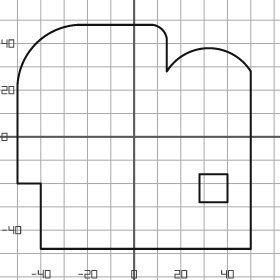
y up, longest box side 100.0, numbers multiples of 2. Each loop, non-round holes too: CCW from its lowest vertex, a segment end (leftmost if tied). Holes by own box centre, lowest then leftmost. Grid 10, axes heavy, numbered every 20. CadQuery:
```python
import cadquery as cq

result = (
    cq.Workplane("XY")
    .moveTo(-40.0, -48.0)
    .lineTo(50.0, -48.0)
    .lineTo(50.0, 28.0)
    .threePointArc((32.0, 38.0), (14.0, 28.0))
    .lineTo(14.0, 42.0)
    .threePointArc((12.0, 46.0), (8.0, 48.0))
    .lineTo(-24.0, 48.0)
    .threePointArc((-42.0, 40.0), (-50.0, 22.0))
    .lineTo(-50.0, -20.0)
    .lineTo(-40.0, -20.0)
    .close()
    .moveTo(28.0, -28.0)
    .lineTo(40.0, -28.0)
    .lineTo(40.0, -16.0)
    .lineTo(28.0, -16.0)
    .close()
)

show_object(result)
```